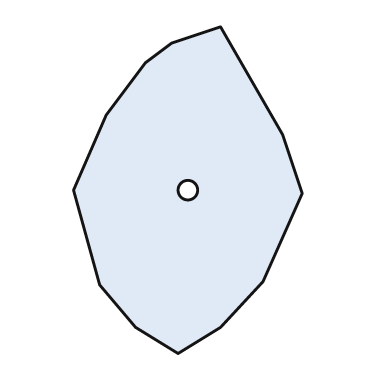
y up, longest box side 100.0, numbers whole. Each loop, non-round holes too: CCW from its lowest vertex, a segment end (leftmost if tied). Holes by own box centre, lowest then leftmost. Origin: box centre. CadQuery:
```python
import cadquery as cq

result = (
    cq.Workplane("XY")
    .moveTo(-3.0, -50.0)
    .lineTo(10.0, -42.0)
    .lineTo(23.0, -28.0)
    .lineTo(35.0, -1.0)
    .lineTo(29.0, 17.0)
    .lineTo(10.0, 50.0)
    .lineTo(-5.0, 45.0)
    .lineTo(-13.0, 39.0)
    .lineTo(-25.0, 23.0)
    .lineTo(-35.0, 0.0)
    .lineTo(-27.0, -29.0)
    .lineTo(-16.0, -42.0)
    .close()
    .moveTo(0.0, 0.0)
    .circle(3.0)
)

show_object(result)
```